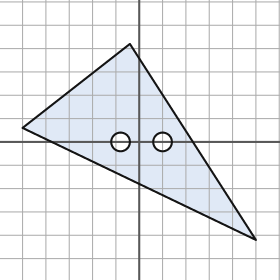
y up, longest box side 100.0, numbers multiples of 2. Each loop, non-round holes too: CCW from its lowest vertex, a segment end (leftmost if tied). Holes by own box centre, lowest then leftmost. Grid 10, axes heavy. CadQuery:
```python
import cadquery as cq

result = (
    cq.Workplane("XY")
    .moveTo(50.0, -42.0)
    .lineTo(-4.0, 42.0)
    .lineTo(-50.0, 6.0)
    .close()
    .moveTo(-8.0, 0.0)
    .circle(4.0)
    .moveTo(10.0, 0.0)
    .circle(4.0)
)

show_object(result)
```